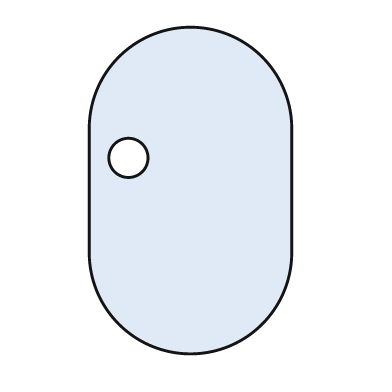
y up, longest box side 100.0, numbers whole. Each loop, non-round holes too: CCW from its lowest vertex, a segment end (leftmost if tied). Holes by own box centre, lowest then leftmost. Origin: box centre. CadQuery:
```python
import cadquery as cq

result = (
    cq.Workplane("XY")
    .moveTo(-31.0, -19.0)
    .threePointArc((0.0, -50.0), (31.0, -19.0))
    .lineTo(31.0, 19.0)
    .threePointArc((0.0, 50.0), (-31.0, 19.0))
    .close()
    .moveTo(-19.0, 10.0)
    .circle(6.0)
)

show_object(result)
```